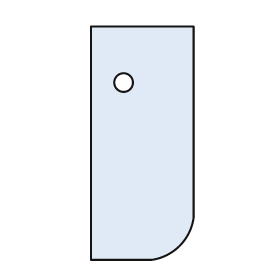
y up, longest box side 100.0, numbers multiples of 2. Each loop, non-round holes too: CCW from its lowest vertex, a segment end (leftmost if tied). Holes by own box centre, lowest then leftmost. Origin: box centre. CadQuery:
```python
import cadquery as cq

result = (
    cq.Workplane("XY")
    .moveTo(-22.0, -50.0)
    .lineTo(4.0, -50.0)
    .threePointArc((16.0, -44.0), (22.0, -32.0))
    .lineTo(22.0, 50.0)
    .lineTo(-22.0, 50.0)
    .close()
    .moveTo(-8.0, 26.0)
    .circle(4.0)
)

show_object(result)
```